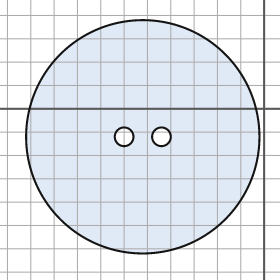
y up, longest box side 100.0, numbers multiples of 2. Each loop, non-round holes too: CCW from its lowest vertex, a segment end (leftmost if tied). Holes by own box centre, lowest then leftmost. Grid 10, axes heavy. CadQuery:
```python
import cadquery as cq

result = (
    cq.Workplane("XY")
    .moveTo(-52.0, -12.0)
    .circle(50.0)
    .moveTo(-60.0, -12.0)
    .circle(4.0)
    .moveTo(-44.0, -12.0)
    .circle(4.0)
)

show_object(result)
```